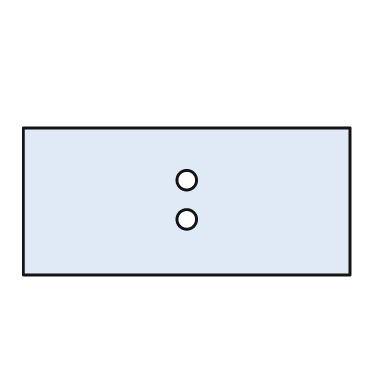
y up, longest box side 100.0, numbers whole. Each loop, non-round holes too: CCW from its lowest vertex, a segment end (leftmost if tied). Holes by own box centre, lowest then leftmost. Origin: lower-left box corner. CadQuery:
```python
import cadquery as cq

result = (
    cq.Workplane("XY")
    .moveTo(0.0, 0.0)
    .lineTo(100.0, 0.0)
    .lineTo(100.0, 45.0)
    .lineTo(0.0, 45.0)
    .close()
    .moveTo(50.0, 17.0)
    .circle(3.0)
    .moveTo(50.0, 29.0)
    .circle(3.0)
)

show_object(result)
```